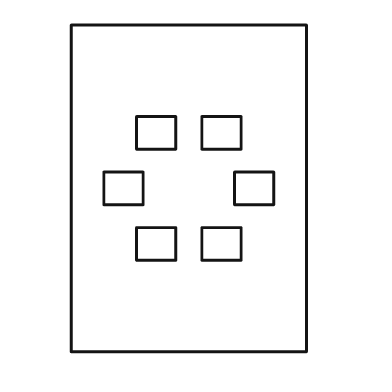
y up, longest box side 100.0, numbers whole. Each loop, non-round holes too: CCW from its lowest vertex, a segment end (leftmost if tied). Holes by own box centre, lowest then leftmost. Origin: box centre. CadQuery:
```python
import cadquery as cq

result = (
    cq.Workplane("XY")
    .moveTo(-36.0, -50.0)
    .lineTo(36.0, -50.0)
    .lineTo(36.0, 50.0)
    .lineTo(-36.0, 50.0)
    .close()
    .moveTo(-16.0, -22.0)
    .lineTo(-4.0, -22.0)
    .lineTo(-4.0, -12.0)
    .lineTo(-16.0, -12.0)
    .close()
    .moveTo(4.0, -22.0)
    .lineTo(16.0, -22.0)
    .lineTo(16.0, -12.0)
    .lineTo(4.0, -12.0)
    .close()
    .moveTo(-26.0, -5.0)
    .lineTo(-14.0, -5.0)
    .lineTo(-14.0, 5.0)
    .lineTo(-26.0, 5.0)
    .close()
    .moveTo(14.0, -5.0)
    .lineTo(26.0, -5.0)
    .lineTo(26.0, 5.0)
    .lineTo(14.0, 5.0)
    .close()
    .moveTo(-16.0, 12.0)
    .lineTo(-4.0, 12.0)
    .lineTo(-4.0, 22.0)
    .lineTo(-16.0, 22.0)
    .close()
    .moveTo(4.0, 12.0)
    .lineTo(16.0, 12.0)
    .lineTo(16.0, 22.0)
    .lineTo(4.0, 22.0)
    .close()
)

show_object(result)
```